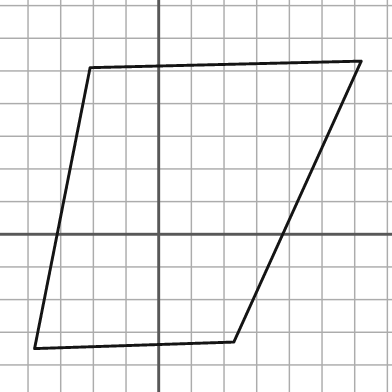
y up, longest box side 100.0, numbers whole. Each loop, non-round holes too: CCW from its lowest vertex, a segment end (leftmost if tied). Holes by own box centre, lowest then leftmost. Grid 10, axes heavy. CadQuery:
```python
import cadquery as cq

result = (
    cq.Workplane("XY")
    .moveTo(-38.0, -35.0)
    .lineTo(23.0, -33.0)
    .lineTo(62.0, 53.0)
    .lineTo(-21.0, 51.0)
    .close()
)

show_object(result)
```